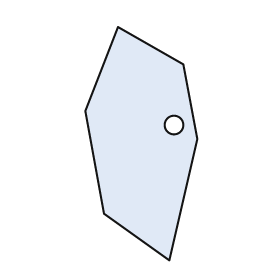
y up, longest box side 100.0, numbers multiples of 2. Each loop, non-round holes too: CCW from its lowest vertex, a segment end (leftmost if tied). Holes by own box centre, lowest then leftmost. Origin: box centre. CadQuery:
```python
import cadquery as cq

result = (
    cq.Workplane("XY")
    .moveTo(12.0, -50.0)
    .lineTo(24.0, 2.0)
    .lineTo(18.0, 34.0)
    .lineTo(-10.0, 50.0)
    .lineTo(-24.0, 14.0)
    .lineTo(-16.0, -30.0)
    .close()
    .moveTo(14.0, 8.0)
    .circle(4.0)
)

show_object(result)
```